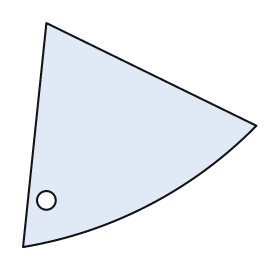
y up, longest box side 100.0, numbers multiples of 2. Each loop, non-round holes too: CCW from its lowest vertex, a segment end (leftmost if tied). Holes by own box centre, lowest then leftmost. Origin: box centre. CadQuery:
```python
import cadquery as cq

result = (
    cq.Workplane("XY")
    .moveTo(-50.0, -48.0)
    .threePointArc((4.0, -30.0), (50.0, 4.0))
    .lineTo(-40.0, 48.0)
    .close()
    .moveTo(-40.0, -28.0)
    .circle(4.0)
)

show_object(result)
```